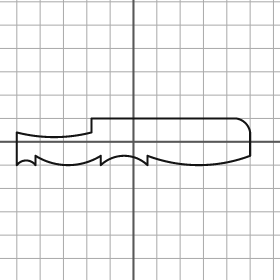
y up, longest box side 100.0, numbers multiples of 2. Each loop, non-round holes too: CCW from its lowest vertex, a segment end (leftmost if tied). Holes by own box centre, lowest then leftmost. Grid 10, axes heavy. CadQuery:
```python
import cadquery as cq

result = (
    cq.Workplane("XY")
    .moveTo(-50.0, -10.0)
    .threePointArc((-46.0, -8.0), (-42.0, -10.0))
    .lineTo(-42.0, -6.0)
    .threePointArc((-28.0, -10.0), (-14.0, -6.0))
    .lineTo(-14.0, -10.0)
    .threePointArc((-4.0, -6.0), (6.0, -10.0))
    .lineTo(6.0, -6.0)
    .threePointArc((28.0, -10.0), (50.0, -6.0))
    .lineTo(50.0, 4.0)
    .threePointArc((48.0, 8.0), (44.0, 10.0))
    .lineTo(-18.0, 10.0)
    .lineTo(-18.0, 4.0)
    .threePointArc((-34.0, 2.0), (-50.0, 4.0))
    .close()
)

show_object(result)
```